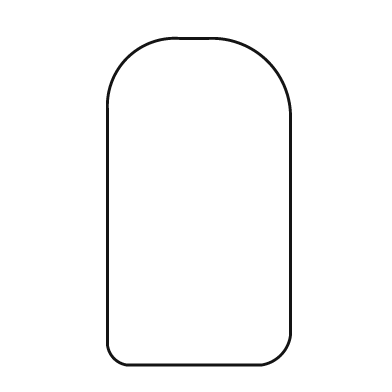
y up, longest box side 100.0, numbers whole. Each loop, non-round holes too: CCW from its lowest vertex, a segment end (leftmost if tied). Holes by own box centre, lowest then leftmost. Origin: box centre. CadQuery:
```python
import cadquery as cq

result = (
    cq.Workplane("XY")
    .moveTo(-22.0, -50.0)
    .lineTo(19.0, -50.0)
    .threePointArc((25.0, -47.0), (28.0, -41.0))
    .lineTo(28.0, 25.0)
    .threePointArc((21.0, 43.0), (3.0, 50.0))
    .lineTo(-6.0, 50.0)
    .threePointArc((-22.0, 44.0), (-28.0, 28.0))
    .lineTo(-28.0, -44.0)
    .threePointArc((-26.0, -48.0), (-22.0, -50.0))
    .close()
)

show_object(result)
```